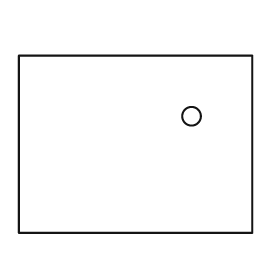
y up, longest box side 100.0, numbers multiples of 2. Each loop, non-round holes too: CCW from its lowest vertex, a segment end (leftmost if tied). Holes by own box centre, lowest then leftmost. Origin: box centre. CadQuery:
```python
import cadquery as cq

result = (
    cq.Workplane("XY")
    .moveTo(-50.0, -38.0)
    .lineTo(50.0, -38.0)
    .lineTo(50.0, 38.0)
    .lineTo(-50.0, 38.0)
    .close()
    .moveTo(24.0, 12.0)
    .circle(4.0)
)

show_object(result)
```